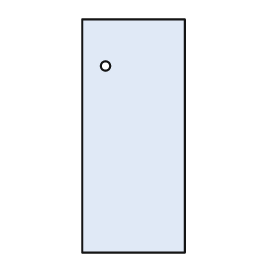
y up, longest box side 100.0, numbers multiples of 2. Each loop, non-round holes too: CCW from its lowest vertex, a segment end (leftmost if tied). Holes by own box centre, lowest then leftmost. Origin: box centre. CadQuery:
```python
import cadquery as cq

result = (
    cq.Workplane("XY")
    .moveTo(-22.0, -50.0)
    .lineTo(22.0, -50.0)
    .lineTo(22.0, 50.0)
    .lineTo(-22.0, 50.0)
    .close()
    .moveTo(-12.0, 30.0)
    .circle(2.0)
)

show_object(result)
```